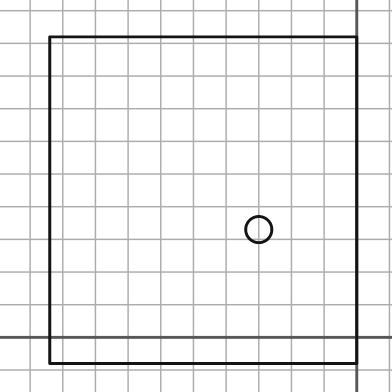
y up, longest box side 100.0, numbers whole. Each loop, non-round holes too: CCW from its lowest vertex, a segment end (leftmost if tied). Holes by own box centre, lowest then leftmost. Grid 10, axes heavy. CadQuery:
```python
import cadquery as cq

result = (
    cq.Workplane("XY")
    .moveTo(-94.0, -8.0)
    .lineTo(0.0, -8.0)
    .lineTo(0.0, 92.0)
    .lineTo(-94.0, 92.0)
    .close()
    .moveTo(-30.0, 33.0)
    .circle(4.0)
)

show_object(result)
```